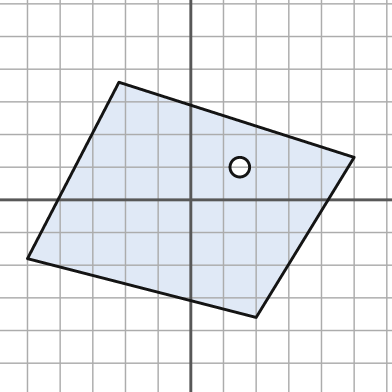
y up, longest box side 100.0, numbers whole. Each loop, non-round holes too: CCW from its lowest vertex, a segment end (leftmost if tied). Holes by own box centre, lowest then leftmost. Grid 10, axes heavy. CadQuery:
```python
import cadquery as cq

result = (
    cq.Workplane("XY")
    .moveTo(20.0, -36.0)
    .lineTo(50.0, 13.0)
    .lineTo(-22.0, 36.0)
    .lineTo(-50.0, -18.0)
    .close()
    .moveTo(15.0, 10.0)
    .circle(3.0)
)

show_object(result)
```